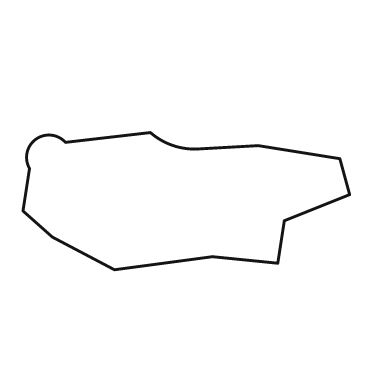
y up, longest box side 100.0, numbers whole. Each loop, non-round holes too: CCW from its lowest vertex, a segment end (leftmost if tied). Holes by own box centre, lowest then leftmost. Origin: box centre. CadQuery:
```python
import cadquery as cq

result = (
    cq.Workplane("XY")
    .moveTo(-22.0, -21.0)
    .lineTo(8.0, -17.0)
    .lineTo(28.0, -19.0)
    .lineTo(30.0, -6.0)
    .lineTo(50.0, 2.0)
    .lineTo(47.0, 13.0)
    .lineTo(22.0, 17.0)
    .lineTo(4.0, 16.0)
    .threePointArc((-4.0, 17.0), (-11.0, 21.0))
    .lineTo(-37.0, 18.0)
    .threePointArc((-46.0, 19.0), (-48.0, 10.0))
    .lineTo(-50.0, -3.0)
    .lineTo(-41.0, -11.0)
    .close()
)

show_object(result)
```